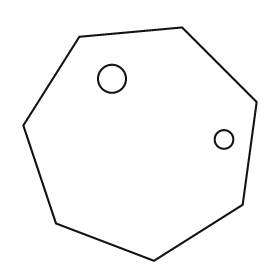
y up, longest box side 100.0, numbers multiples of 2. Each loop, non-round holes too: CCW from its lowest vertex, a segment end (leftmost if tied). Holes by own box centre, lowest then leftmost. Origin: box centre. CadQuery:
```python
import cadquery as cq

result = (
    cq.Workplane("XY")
    .moveTo(6.0, -50.0)
    .lineTo(44.0, -26.0)
    .lineTo(50.0, 18.0)
    .lineTo(18.0, 50.0)
    .lineTo(-26.0, 46.0)
    .lineTo(-50.0, 8.0)
    .lineTo(-36.0, -34.0)
    .close()
    .moveTo(36.0, 2.0)
    .circle(4.0)
    .moveTo(-12.0, 28.0)
    .circle(6.0)
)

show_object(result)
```